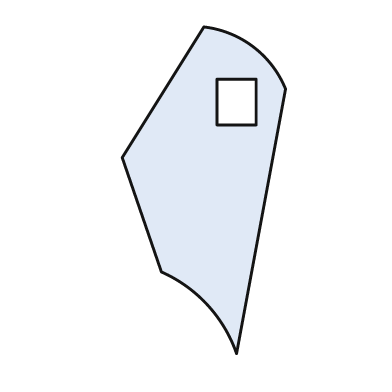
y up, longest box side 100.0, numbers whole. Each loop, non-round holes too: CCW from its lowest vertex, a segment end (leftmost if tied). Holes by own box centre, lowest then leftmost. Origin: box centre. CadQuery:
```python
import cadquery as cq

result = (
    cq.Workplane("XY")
    .moveTo(10.0, -50.0)
    .lineTo(25.0, 31.0)
    .threePointArc((15.0, 44.0), (0.0, 50.0))
    .lineTo(-25.0, 10.0)
    .lineTo(-13.0, -25.0)
    .threePointArc((1.0, -35.0), (10.0, -50.0))
    .close()
    .moveTo(4.0, 20.0)
    .lineTo(16.0, 20.0)
    .lineTo(16.0, 34.0)
    .lineTo(4.0, 34.0)
    .close()
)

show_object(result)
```